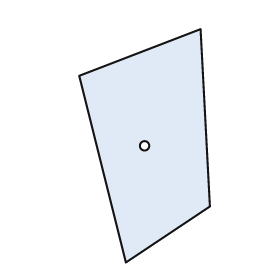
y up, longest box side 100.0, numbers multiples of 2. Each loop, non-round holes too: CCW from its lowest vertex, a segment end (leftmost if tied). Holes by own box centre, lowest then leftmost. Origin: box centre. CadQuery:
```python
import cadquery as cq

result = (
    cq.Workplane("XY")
    .moveTo(-8.0, -50.0)
    .lineTo(28.0, -26.0)
    .lineTo(24.0, 50.0)
    .lineTo(-28.0, 30.0)
    .close()
    .moveTo(0.0, 0.0)
    .circle(2.0)
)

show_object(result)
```